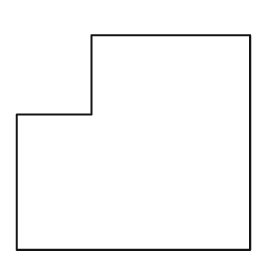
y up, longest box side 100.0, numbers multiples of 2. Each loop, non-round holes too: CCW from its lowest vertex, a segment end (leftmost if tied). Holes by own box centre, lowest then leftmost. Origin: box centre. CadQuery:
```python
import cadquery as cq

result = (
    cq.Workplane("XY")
    .moveTo(-50.0, -46.0)
    .lineTo(50.0, -46.0)
    .lineTo(50.0, 46.0)
    .lineTo(-18.0, 46.0)
    .lineTo(-18.0, 12.0)
    .lineTo(-50.0, 12.0)
    .close()
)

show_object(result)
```